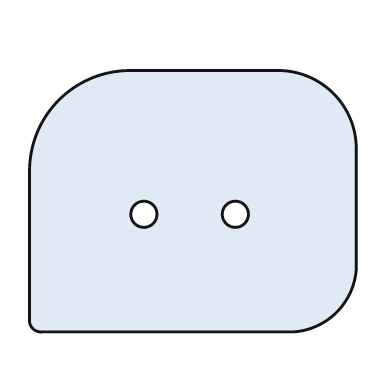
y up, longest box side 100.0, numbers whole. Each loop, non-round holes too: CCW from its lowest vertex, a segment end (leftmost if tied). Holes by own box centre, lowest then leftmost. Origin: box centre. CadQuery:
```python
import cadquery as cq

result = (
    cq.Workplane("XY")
    .moveTo(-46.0, -40.0)
    .lineTo(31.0, -40.0)
    .threePointArc((44.0, -34.0), (50.0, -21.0))
    .lineTo(50.0, 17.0)
    .threePointArc((43.0, 33.0), (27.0, 40.0))
    .lineTo(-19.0, 40.0)
    .threePointArc((-41.0, 31.0), (-50.0, 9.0))
    .lineTo(-50.0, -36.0)
    .threePointArc((-49.0, -39.0), (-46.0, -40.0))
    .close()
    .moveTo(-15.0, -4.0)
    .circle(4.0)
    .moveTo(13.0, -4.0)
    .circle(4.0)
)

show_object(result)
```